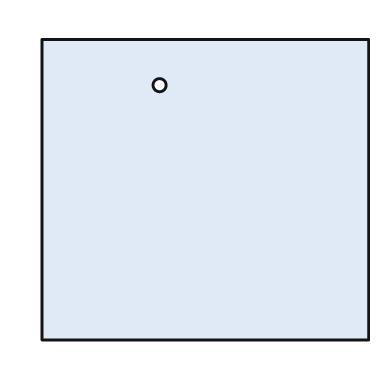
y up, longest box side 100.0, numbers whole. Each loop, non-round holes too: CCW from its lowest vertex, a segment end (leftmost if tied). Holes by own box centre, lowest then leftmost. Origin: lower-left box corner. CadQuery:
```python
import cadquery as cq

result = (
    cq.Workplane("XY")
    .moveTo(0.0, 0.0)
    .lineTo(100.0, 0.0)
    .lineTo(100.0, 92.0)
    .lineTo(0.0, 92.0)
    .close()
    .moveTo(36.0, 78.0)
    .circle(2.0)
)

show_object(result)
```